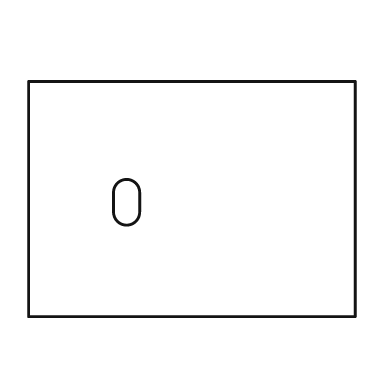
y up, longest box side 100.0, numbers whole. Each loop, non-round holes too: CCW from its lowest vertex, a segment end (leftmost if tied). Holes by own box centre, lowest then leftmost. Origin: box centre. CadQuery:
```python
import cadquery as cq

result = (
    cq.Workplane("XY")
    .moveTo(-50.0, -36.0)
    .lineTo(50.0, -36.0)
    .lineTo(50.0, 36.0)
    .lineTo(-50.0, 36.0)
    .close()
    .moveTo(-24.0, -4.0)
    .threePointArc((-20.0, -8.0), (-16.0, -4.0))
    .lineTo(-16.0, 2.0)
    .threePointArc((-20.0, 6.0), (-24.0, 2.0))
    .close()
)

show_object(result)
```